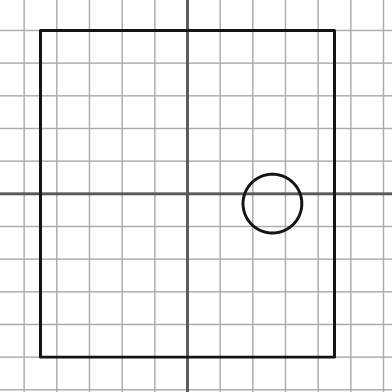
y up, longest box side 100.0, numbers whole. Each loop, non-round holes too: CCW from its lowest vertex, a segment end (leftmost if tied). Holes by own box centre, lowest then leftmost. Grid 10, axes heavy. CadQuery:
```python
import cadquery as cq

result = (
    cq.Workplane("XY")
    .moveTo(-45.0, -50.0)
    .lineTo(45.0, -50.0)
    .lineTo(45.0, 50.0)
    .lineTo(-45.0, 50.0)
    .close()
    .moveTo(26.0, -3.0)
    .circle(9.0)
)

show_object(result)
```